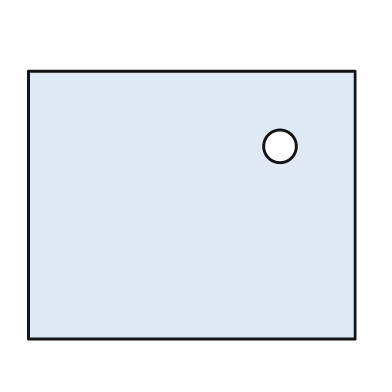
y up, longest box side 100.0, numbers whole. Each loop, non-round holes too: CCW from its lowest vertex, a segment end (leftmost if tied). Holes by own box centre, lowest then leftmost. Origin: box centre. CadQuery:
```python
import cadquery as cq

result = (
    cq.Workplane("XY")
    .moveTo(-50.0, -41.0)
    .lineTo(50.0, -41.0)
    .lineTo(50.0, 41.0)
    .lineTo(-50.0, 41.0)
    .close()
    .moveTo(27.0, 18.0)
    .circle(5.0)
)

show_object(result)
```